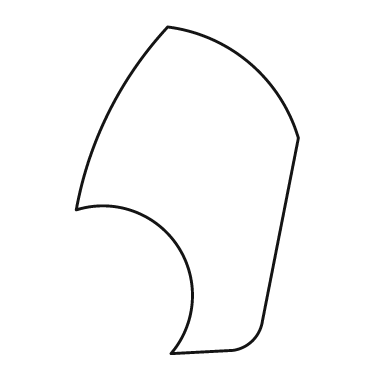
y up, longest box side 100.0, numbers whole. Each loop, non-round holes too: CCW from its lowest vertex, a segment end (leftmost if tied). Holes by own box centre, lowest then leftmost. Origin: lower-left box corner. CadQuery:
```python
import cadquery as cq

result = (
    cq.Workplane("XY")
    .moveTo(29.0, 0.0)
    .lineTo(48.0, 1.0)
    .threePointArc((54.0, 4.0), (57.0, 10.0))
    .lineTo(68.0, 66.0)
    .threePointArc((53.0, 89.0), (28.0, 100.0))
    .threePointArc((10.0, 74.0), (0.0, 44.0))
    .threePointArc((31.0, 33.0), (29.0, 0.0))
    .close()
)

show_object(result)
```